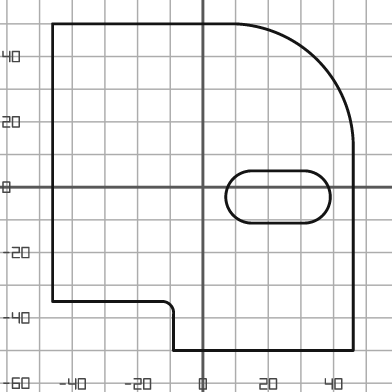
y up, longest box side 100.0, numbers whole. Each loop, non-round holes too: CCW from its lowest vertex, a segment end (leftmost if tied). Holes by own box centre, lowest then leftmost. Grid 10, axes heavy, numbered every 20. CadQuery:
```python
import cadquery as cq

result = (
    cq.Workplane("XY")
    .moveTo(-9.0, -50.0)
    .lineTo(46.0, -50.0)
    .lineTo(46.0, 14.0)
    .threePointArc((35.0, 39.0), (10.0, 50.0))
    .lineTo(-46.0, 50.0)
    .lineTo(-46.0, -35.0)
    .lineTo(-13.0, -35.0)
    .threePointArc((-10.0, -36.0), (-9.0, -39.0))
    .close()
    .moveTo(15.0, -11.0)
    .lineTo(31.0, -11.0)
    .threePointArc((39.0, -3.0), (31.0, 5.0))
    .lineTo(15.0, 5.0)
    .threePointArc((7.0, -3.0), (15.0, -11.0))
    .close()
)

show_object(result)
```